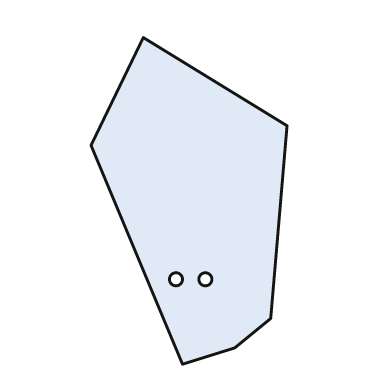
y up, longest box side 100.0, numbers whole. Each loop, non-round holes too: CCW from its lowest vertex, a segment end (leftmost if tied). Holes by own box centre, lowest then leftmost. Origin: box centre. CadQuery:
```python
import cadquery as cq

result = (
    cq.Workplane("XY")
    .moveTo(-2.0, -50.0)
    .lineTo(14.0, -45.0)
    .lineTo(25.0, -36.0)
    .lineTo(30.0, 23.0)
    .lineTo(-14.0, 50.0)
    .lineTo(-30.0, 17.0)
    .close()
    .moveTo(-4.0, -24.0)
    .circle(2.0)
    .moveTo(5.0, -24.0)
    .circle(2.0)
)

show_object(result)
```